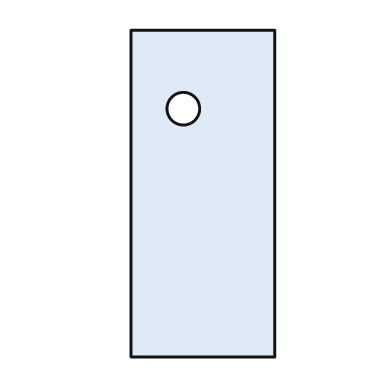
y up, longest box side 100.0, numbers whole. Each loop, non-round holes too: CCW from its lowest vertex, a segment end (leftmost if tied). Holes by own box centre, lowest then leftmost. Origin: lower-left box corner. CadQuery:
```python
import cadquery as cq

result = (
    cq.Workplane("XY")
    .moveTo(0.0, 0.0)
    .lineTo(44.0, 0.0)
    .lineTo(44.0, 100.0)
    .lineTo(0.0, 100.0)
    .close()
    .moveTo(16.0, 76.0)
    .circle(5.0)
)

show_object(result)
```